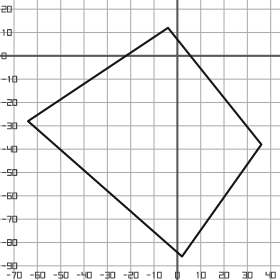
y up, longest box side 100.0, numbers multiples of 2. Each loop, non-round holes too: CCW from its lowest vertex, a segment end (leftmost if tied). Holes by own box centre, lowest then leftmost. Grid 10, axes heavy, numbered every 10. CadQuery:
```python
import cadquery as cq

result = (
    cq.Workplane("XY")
    .moveTo(2.0, -86.0)
    .lineTo(36.0, -38.0)
    .lineTo(-4.0, 12.0)
    .lineTo(-64.0, -28.0)
    .close()
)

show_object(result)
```